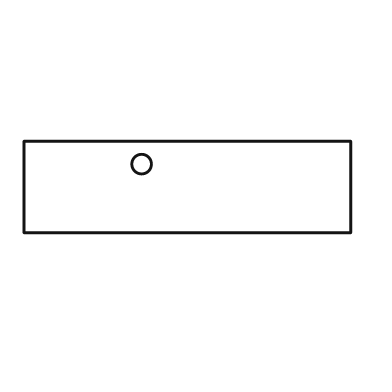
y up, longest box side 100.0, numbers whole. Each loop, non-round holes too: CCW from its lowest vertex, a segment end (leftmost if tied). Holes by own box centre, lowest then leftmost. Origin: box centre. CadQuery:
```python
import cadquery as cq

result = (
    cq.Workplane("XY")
    .moveTo(-50.0, -14.0)
    .lineTo(50.0, -14.0)
    .lineTo(50.0, 14.0)
    .lineTo(-50.0, 14.0)
    .close()
    .moveTo(-14.0, 7.0)
    .circle(3.0)
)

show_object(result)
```